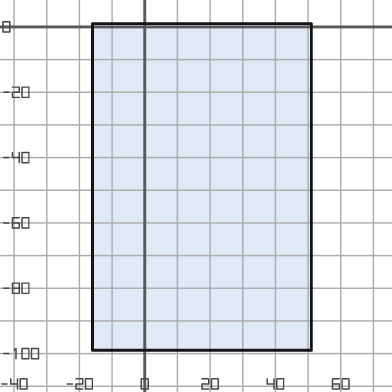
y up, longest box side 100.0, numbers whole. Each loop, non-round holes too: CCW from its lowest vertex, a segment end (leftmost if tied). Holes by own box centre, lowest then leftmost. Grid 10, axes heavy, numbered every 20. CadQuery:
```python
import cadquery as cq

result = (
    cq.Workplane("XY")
    .moveTo(-16.0, -99.0)
    .lineTo(51.0, -99.0)
    .lineTo(51.0, 1.0)
    .lineTo(-16.0, 1.0)
    .close()
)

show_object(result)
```